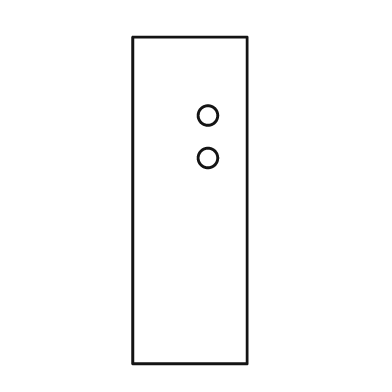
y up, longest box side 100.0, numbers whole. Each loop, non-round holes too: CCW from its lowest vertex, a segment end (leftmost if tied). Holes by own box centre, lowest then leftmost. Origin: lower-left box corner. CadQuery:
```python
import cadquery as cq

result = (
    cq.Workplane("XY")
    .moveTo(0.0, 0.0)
    .lineTo(35.0, 0.0)
    .lineTo(35.0, 100.0)
    .lineTo(0.0, 100.0)
    .close()
    .moveTo(23.0, 63.0)
    .circle(3.0)
    .moveTo(23.0, 76.0)
    .circle(3.0)
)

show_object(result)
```